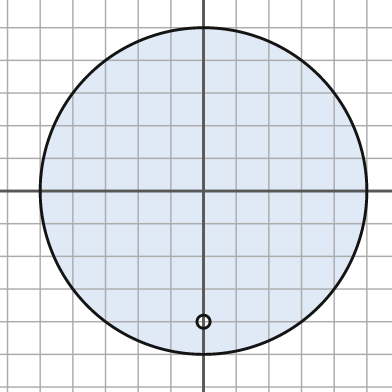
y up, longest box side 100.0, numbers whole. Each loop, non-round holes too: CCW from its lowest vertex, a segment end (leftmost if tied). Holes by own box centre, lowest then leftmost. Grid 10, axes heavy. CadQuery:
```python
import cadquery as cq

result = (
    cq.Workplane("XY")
    .moveTo(0.0, 0.0)
    .circle(50.0)
    .moveTo(0.0, -40.0)
    .circle(2.0)
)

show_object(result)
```